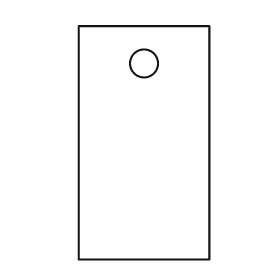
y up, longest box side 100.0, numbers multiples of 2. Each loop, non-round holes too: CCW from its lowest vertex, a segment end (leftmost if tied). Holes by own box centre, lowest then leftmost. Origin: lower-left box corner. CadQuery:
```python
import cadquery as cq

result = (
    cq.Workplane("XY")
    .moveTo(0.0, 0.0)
    .lineTo(56.0, 0.0)
    .lineTo(56.0, 100.0)
    .lineTo(0.0, 100.0)
    .close()
    .moveTo(28.0, 84.0)
    .circle(6.0)
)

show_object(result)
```